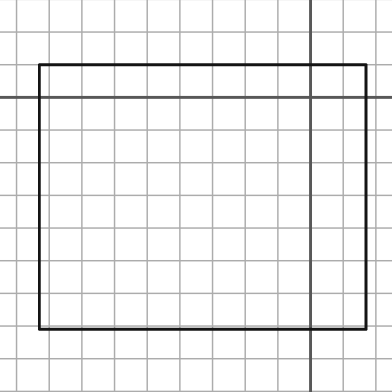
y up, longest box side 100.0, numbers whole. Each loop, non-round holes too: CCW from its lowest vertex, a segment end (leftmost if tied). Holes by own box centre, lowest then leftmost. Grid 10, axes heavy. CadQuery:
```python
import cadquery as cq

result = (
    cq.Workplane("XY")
    .moveTo(-83.0, -71.0)
    .lineTo(17.0, -71.0)
    .lineTo(17.0, 10.0)
    .lineTo(-83.0, 10.0)
    .close()
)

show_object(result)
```